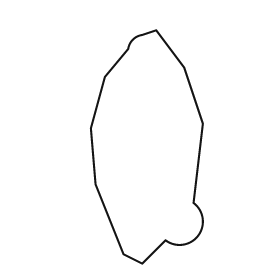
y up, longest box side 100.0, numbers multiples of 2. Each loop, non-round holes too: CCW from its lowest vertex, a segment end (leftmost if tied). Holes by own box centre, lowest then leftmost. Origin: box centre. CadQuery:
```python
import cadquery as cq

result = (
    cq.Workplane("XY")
    .moveTo(-2.0, -50.0)
    .lineTo(8.0, -40.0)
    .threePointArc((22.0, -38.0), (20.0, -24.0))
    .lineTo(24.0, 10.0)
    .lineTo(16.0, 34.0)
    .lineTo(4.0, 50.0)
    .lineTo(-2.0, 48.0)
    .threePointArc((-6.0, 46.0), (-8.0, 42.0))
    .lineTo(-18.0, 30.0)
    .lineTo(-24.0, 8.0)
    .lineTo(-22.0, -16.0)
    .lineTo(-10.0, -46.0)
    .close()
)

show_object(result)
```